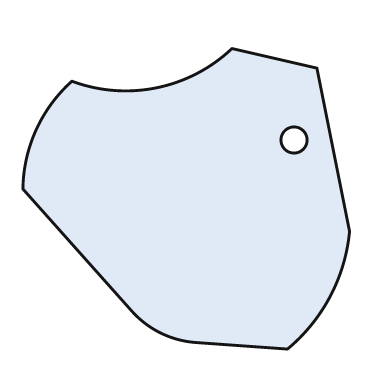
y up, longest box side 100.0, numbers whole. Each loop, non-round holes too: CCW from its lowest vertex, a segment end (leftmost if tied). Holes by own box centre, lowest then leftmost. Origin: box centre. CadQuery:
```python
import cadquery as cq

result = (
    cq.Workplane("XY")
    .moveTo(31.0, -46.0)
    .threePointArc((44.0, -30.0), (50.0, -10.0))
    .lineTo(40.0, 40.0)
    .lineTo(14.0, 46.0)
    .threePointArc((-9.0, 34.0), (-35.0, 36.0))
    .threePointArc((-46.0, 21.0), (-50.0, 3.0))
    .lineTo(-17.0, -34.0)
    .threePointArc((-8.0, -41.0), (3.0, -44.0))
    .close()
    .moveTo(33.0, 18.0)
    .circle(4.0)
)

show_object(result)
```